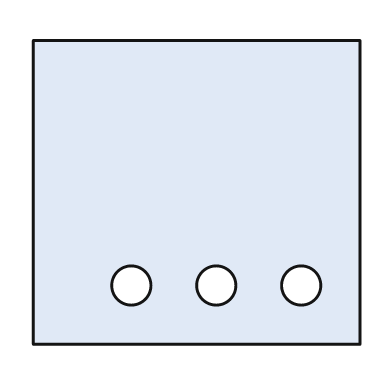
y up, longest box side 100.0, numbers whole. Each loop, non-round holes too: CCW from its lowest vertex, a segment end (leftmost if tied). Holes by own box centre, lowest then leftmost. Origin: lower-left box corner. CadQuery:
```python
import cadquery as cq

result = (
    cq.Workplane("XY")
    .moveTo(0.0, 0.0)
    .lineTo(100.0, 0.0)
    .lineTo(100.0, 93.0)
    .lineTo(0.0, 93.0)
    .close()
    .moveTo(30.0, 18.0)
    .circle(6.0)
    .moveTo(56.0, 18.0)
    .circle(6.0)
    .moveTo(82.0, 18.0)
    .circle(6.0)
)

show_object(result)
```